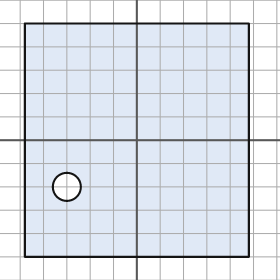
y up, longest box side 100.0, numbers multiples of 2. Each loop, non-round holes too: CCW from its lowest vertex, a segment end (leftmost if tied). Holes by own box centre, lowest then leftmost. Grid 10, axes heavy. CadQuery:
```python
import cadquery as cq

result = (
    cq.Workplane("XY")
    .moveTo(-48.0, -50.0)
    .lineTo(48.0, -50.0)
    .lineTo(48.0, 50.0)
    .lineTo(-48.0, 50.0)
    .close()
    .moveTo(-30.0, -20.0)
    .circle(6.0)
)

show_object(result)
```